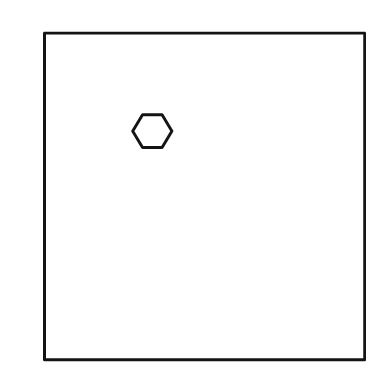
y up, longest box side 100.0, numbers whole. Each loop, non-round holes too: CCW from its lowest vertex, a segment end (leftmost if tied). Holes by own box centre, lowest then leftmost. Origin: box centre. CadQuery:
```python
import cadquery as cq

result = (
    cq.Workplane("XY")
    .moveTo(-49.0, -50.0)
    .lineTo(49.0, -50.0)
    .lineTo(49.0, 50.0)
    .lineTo(-49.0, 50.0)
    .close()
    .moveTo(-19.0, 15.0)
    .lineTo(-13.0, 15.0)
    .lineTo(-10.0, 20.0)
    .lineTo(-13.0, 25.0)
    .lineTo(-19.0, 25.0)
    .lineTo(-22.0, 20.0)
    .close()
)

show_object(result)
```